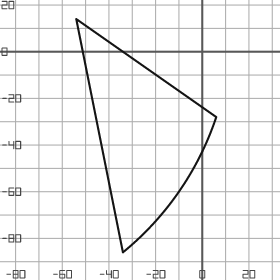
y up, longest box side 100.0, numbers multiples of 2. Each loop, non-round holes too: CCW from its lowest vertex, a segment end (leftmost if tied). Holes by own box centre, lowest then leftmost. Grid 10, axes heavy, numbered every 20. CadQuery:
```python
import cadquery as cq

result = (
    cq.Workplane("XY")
    .moveTo(-34.0, -86.0)
    .threePointArc((-10.0, -60.0), (6.0, -28.0))
    .lineTo(-54.0, 14.0)
    .close()
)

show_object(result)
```